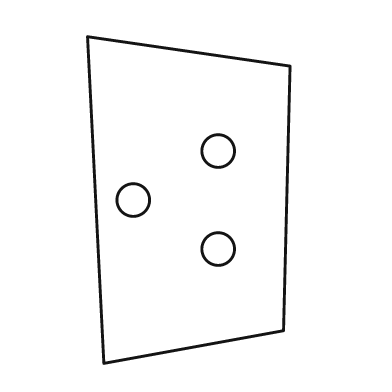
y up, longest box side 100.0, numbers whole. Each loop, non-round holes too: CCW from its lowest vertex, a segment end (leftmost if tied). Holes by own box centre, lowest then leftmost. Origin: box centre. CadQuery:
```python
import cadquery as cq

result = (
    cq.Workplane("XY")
    .moveTo(-26.0, -50.0)
    .lineTo(29.0, -40.0)
    .lineTo(31.0, 41.0)
    .lineTo(-31.0, 50.0)
    .close()
    .moveTo(9.0, -15.0)
    .circle(5.0)
    .moveTo(-17.0, 0.0)
    .circle(5.0)
    .moveTo(9.0, 15.0)
    .circle(5.0)
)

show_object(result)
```